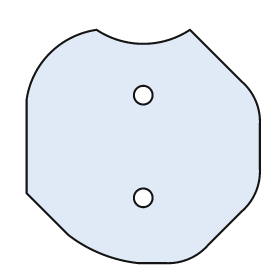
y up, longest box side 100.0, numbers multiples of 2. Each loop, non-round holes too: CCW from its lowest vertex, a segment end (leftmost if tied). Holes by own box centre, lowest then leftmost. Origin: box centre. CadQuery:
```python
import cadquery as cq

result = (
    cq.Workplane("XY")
    .moveTo(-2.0, -50.0)
    .lineTo(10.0, -50.0)
    .threePointArc((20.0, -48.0), (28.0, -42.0))
    .lineTo(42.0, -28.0)
    .threePointArc((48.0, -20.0), (50.0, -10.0))
    .lineTo(50.0, 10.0)
    .threePointArc((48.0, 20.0), (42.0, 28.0))
    .lineTo(20.0, 50.0)
    .threePointArc((0.0, 44.0), (-20.0, 50.0))
    .threePointArc((-40.0, 40.0), (-50.0, 20.0))
    .lineTo(-50.0, -20.0)
    .lineTo(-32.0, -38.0)
    .threePointArc((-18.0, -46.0), (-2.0, -50.0))
    .close()
    .moveTo(0.0, -22.0)
    .circle(4.0)
    .moveTo(0.0, 22.0)
    .circle(4.0)
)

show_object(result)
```